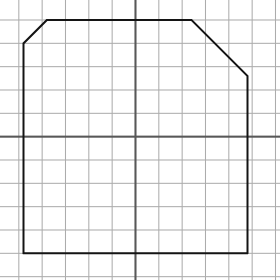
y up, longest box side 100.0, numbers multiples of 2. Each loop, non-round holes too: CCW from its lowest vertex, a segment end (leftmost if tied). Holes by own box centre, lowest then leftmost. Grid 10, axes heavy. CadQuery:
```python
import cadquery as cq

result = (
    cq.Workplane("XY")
    .moveTo(-48.0, -50.0)
    .lineTo(48.0, -50.0)
    .lineTo(48.0, 26.0)
    .lineTo(24.0, 50.0)
    .lineTo(-38.0, 50.0)
    .lineTo(-48.0, 40.0)
    .close()
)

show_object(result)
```